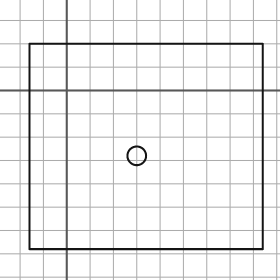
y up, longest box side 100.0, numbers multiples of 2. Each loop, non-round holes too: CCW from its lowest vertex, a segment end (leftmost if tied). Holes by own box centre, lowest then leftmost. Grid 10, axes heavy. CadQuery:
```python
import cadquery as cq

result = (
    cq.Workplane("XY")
    .moveTo(-16.0, -68.0)
    .lineTo(84.0, -68.0)
    .lineTo(84.0, 20.0)
    .lineTo(-16.0, 20.0)
    .close()
    .moveTo(30.0, -28.0)
    .circle(4.0)
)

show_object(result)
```